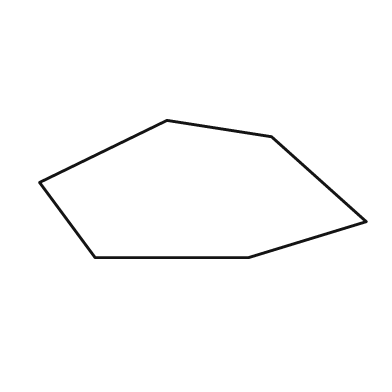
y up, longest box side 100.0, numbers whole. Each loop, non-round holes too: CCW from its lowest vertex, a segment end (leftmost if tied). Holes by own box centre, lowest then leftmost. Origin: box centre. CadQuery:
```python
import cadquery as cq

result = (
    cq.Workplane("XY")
    .moveTo(-33.0, -21.0)
    .lineTo(14.0, -21.0)
    .lineTo(50.0, -10.0)
    .lineTo(21.0, 16.0)
    .lineTo(-11.0, 21.0)
    .lineTo(-50.0, 2.0)
    .close()
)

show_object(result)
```